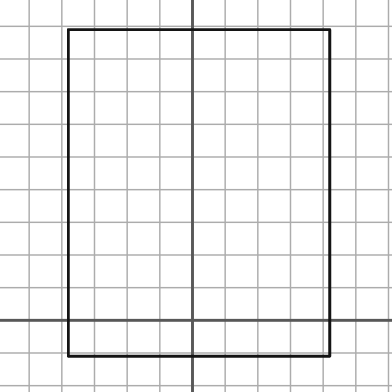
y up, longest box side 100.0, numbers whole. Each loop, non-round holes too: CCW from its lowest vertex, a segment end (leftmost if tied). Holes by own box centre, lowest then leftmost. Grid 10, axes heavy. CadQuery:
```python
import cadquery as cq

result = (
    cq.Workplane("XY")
    .moveTo(-38.0, -11.0)
    .lineTo(42.0, -11.0)
    .lineTo(42.0, 89.0)
    .lineTo(-38.0, 89.0)
    .close()
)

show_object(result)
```